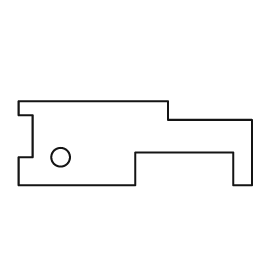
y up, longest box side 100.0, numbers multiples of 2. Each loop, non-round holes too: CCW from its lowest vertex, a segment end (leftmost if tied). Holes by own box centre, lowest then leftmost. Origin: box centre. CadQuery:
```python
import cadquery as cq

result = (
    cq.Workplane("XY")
    .moveTo(-50.0, -18.0)
    .lineTo(0.0, -18.0)
    .lineTo(0.0, -4.0)
    .lineTo(42.0, -4.0)
    .lineTo(42.0, -18.0)
    .lineTo(50.0, -18.0)
    .lineTo(50.0, 10.0)
    .lineTo(14.0, 10.0)
    .lineTo(14.0, 18.0)
    .lineTo(-50.0, 18.0)
    .lineTo(-50.0, 12.0)
    .lineTo(-44.0, 12.0)
    .lineTo(-44.0, -6.0)
    .lineTo(-50.0, -6.0)
    .close()
    .moveTo(-32.0, -6.0)
    .circle(4.0)
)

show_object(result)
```